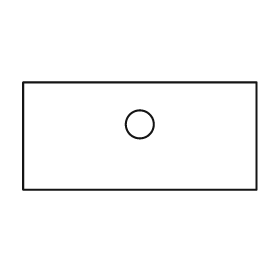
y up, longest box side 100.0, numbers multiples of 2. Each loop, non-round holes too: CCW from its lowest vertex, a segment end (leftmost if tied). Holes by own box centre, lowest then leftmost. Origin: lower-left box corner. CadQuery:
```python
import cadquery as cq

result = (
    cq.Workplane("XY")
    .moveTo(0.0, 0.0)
    .lineTo(100.0, 0.0)
    .lineTo(100.0, 46.0)
    .lineTo(0.0, 46.0)
    .close()
    .moveTo(50.0, 28.0)
    .circle(6.0)
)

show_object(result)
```